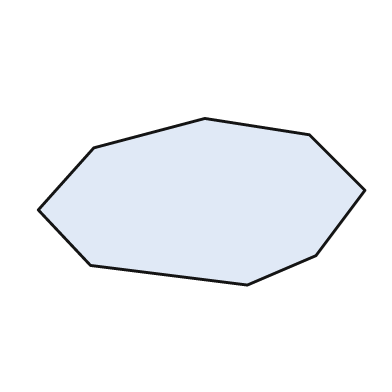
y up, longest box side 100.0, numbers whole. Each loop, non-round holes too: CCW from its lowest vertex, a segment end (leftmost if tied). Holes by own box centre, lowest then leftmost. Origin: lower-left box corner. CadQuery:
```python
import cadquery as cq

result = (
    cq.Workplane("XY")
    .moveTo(64.0, 0.0)
    .lineTo(85.0, 9.0)
    .lineTo(100.0, 29.0)
    .lineTo(83.0, 46.0)
    .lineTo(51.0, 51.0)
    .lineTo(17.0, 42.0)
    .lineTo(0.0, 23.0)
    .lineTo(16.0, 6.0)
    .close()
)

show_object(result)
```